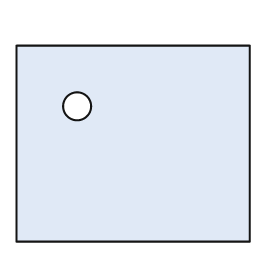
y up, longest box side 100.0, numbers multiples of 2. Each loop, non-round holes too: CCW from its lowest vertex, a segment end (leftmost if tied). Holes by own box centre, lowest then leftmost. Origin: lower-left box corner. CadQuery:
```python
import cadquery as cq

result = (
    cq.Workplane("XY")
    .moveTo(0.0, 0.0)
    .lineTo(100.0, 0.0)
    .lineTo(100.0, 84.0)
    .lineTo(0.0, 84.0)
    .close()
    .moveTo(26.0, 58.0)
    .circle(6.0)
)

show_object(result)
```